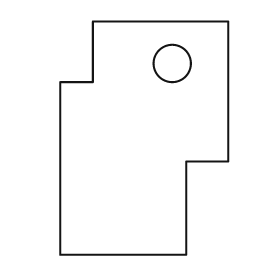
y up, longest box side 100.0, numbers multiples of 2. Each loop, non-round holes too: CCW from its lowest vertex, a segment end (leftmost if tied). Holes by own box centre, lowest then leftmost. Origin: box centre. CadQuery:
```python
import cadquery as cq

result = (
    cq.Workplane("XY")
    .moveTo(-36.0, -50.0)
    .lineTo(18.0, -50.0)
    .lineTo(18.0, -10.0)
    .lineTo(36.0, -10.0)
    .lineTo(36.0, 50.0)
    .lineTo(-22.0, 50.0)
    .lineTo(-22.0, 24.0)
    .lineTo(-36.0, 24.0)
    .close()
    .moveTo(12.0, 32.0)
    .circle(8.0)
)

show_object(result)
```